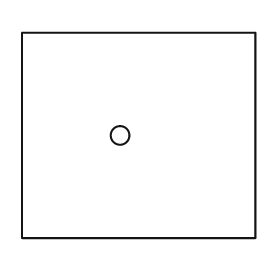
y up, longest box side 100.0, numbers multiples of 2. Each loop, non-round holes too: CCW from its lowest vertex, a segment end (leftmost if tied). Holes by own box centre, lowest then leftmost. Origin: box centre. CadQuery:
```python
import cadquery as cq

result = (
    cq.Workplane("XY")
    .moveTo(-50.0, -44.0)
    .lineTo(50.0, -44.0)
    .lineTo(50.0, 44.0)
    .lineTo(-50.0, 44.0)
    .close()
    .moveTo(-8.0, 0.0)
    .circle(4.0)
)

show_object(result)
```